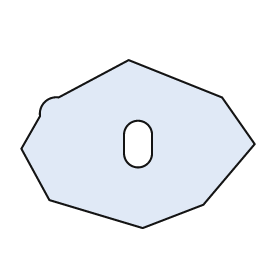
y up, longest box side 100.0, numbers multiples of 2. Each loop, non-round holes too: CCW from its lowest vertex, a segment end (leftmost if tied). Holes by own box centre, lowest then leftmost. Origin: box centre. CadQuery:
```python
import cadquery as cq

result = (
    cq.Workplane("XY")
    .moveTo(2.0, -36.0)
    .lineTo(28.0, -26.0)
    .lineTo(50.0, 0.0)
    .lineTo(36.0, 20.0)
    .lineTo(-4.0, 36.0)
    .lineTo(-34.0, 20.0)
    .threePointArc((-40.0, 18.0), (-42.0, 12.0))
    .lineTo(-50.0, -2.0)
    .lineTo(-38.0, -24.0)
    .close()
    .moveTo(-6.0, -4.0)
    .threePointArc((0.0, -10.0), (6.0, -4.0))
    .lineTo(6.0, 4.0)
    .threePointArc((0.0, 10.0), (-6.0, 4.0))
    .close()
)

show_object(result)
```